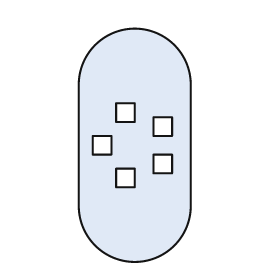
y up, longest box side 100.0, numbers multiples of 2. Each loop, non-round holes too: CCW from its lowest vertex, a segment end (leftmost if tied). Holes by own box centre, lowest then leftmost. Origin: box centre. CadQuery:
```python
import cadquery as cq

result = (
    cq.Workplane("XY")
    .moveTo(-24.0, -26.0)
    .threePointArc((0.0, -50.0), (24.0, -26.0))
    .lineTo(24.0, 26.0)
    .threePointArc((0.0, 50.0), (-24.0, 26.0))
    .close()
    .moveTo(-8.0, -18.0)
    .lineTo(0.0, -18.0)
    .lineTo(0.0, -10.0)
    .lineTo(-8.0, -10.0)
    .close()
    .moveTo(8.0, -12.0)
    .lineTo(16.0, -12.0)
    .lineTo(16.0, -4.0)
    .lineTo(8.0, -4.0)
    .close()
    .moveTo(-18.0, -4.0)
    .lineTo(-10.0, -4.0)
    .lineTo(-10.0, 4.0)
    .lineTo(-18.0, 4.0)
    .close()
    .moveTo(8.0, 4.0)
    .lineTo(16.0, 4.0)
    .lineTo(16.0, 12.0)
    .lineTo(8.0, 12.0)
    .close()
    .moveTo(-8.0, 10.0)
    .lineTo(0.0, 10.0)
    .lineTo(0.0, 18.0)
    .lineTo(-8.0, 18.0)
    .close()
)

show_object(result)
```